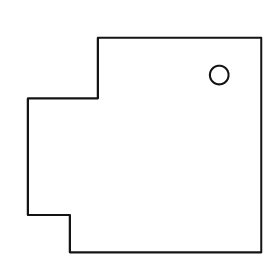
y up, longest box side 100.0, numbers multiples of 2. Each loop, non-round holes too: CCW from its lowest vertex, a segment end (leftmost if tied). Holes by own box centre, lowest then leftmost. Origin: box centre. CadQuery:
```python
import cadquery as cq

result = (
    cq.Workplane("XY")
    .moveTo(-32.0, -46.0)
    .lineTo(50.0, -46.0)
    .lineTo(50.0, 46.0)
    .lineTo(-20.0, 46.0)
    .lineTo(-20.0, 20.0)
    .lineTo(-50.0, 20.0)
    .lineTo(-50.0, -30.0)
    .lineTo(-32.0, -30.0)
    .close()
    .moveTo(32.0, 30.0)
    .circle(4.0)
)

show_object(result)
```